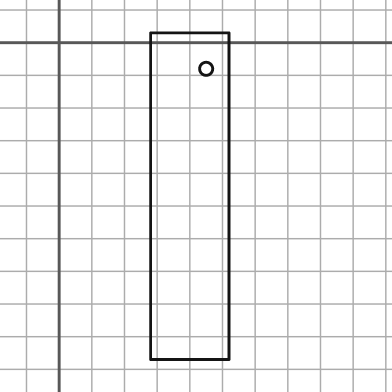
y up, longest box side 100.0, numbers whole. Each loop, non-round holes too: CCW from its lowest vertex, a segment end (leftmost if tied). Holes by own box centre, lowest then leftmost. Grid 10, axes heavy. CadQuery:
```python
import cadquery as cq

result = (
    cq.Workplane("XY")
    .moveTo(28.0, -97.0)
    .lineTo(52.0, -97.0)
    .lineTo(52.0, 3.0)
    .lineTo(28.0, 3.0)
    .close()
    .moveTo(45.0, -8.0)
    .circle(2.0)
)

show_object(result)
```